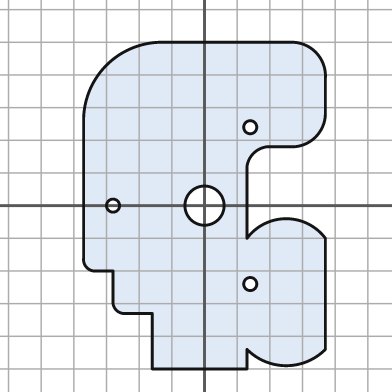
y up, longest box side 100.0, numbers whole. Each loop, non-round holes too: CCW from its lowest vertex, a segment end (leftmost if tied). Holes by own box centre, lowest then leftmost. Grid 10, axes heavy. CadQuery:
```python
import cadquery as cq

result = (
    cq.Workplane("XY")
    .moveTo(-16.0, -50.0)
    .lineTo(13.0, -50.0)
    .lineTo(13.0, -44.0)
    .threePointArc((25.0, -49.0), (37.0, -44.0))
    .lineTo(37.0, -10.0)
    .threePointArc((25.0, -4.0), (13.0, -10.0))
    .lineTo(13.0, 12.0)
    .threePointArc((15.0, 16.0), (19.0, 18.0))
    .lineTo(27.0, 18.0)
    .threePointArc((34.0, 21.0), (37.0, 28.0))
    .lineTo(37.0, 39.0)
    .threePointArc((34.0, 47.0), (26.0, 50.0))
    .lineTo(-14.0, 50.0)
    .threePointArc((-30.0, 43.0), (-37.0, 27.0))
    .lineTo(-37.0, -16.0)
    .threePointArc((-36.0, -19.0), (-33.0, -20.0))
    .lineTo(-28.0, -20.0)
    .lineTo(-28.0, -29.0)
    .threePointArc((-27.0, -32.0), (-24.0, -33.0))
    .lineTo(-16.0, -33.0)
    .close()
    .moveTo(14.0, -24.0)
    .circle(2.0)
    .moveTo(-28.0, 0.0)
    .circle(2.0)
    .moveTo(0.0, 0.0)
    .circle(6.0)
    .moveTo(14.0, 24.0)
    .circle(2.0)
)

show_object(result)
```